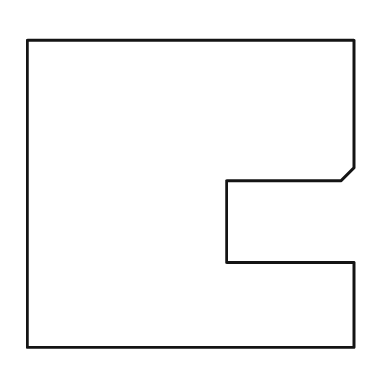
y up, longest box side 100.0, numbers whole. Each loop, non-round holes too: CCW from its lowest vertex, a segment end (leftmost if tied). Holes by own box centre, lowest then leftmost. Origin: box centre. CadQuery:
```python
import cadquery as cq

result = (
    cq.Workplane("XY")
    .moveTo(-50.0, -47.0)
    .lineTo(50.0, -47.0)
    .lineTo(50.0, -21.0)
    .lineTo(11.0, -21.0)
    .lineTo(11.0, 4.0)
    .lineTo(46.0, 4.0)
    .lineTo(50.0, 8.0)
    .lineTo(50.0, 47.0)
    .lineTo(-50.0, 47.0)
    .close()
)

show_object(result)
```